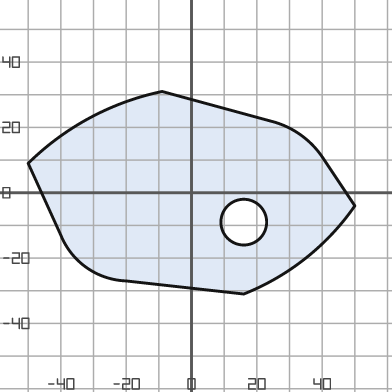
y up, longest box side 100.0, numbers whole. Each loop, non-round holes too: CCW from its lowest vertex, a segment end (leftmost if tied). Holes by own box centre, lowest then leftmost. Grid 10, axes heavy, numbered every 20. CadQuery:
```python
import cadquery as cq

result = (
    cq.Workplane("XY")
    .moveTo(16.0, -31.0)
    .threePointArc((35.0, -20.0), (50.0, -4.0))
    .lineTo(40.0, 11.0)
    .threePointArc((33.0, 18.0), (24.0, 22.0))
    .lineTo(-9.0, 31.0)
    .threePointArc((-31.0, 23.0), (-50.0, 9.0))
    .lineTo(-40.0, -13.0)
    .threePointArc((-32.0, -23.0), (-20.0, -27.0))
    .close()
    .moveTo(16.0, -9.0)
    .circle(7.0)
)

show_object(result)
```